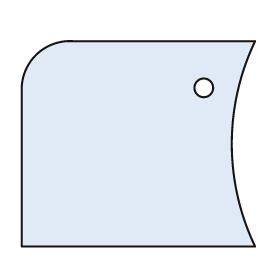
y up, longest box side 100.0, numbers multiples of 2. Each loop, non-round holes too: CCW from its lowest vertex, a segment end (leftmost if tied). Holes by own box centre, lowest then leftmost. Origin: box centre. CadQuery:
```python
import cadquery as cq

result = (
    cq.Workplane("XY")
    .moveTo(-50.0, -44.0)
    .lineTo(50.0, -44.0)
    .threePointArc((40.0, 0.0), (50.0, 44.0))
    .lineTo(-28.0, 44.0)
    .threePointArc((-44.0, 38.0), (-50.0, 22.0))
    .close()
    .moveTo(28.0, 24.0)
    .circle(4.0)
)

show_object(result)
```